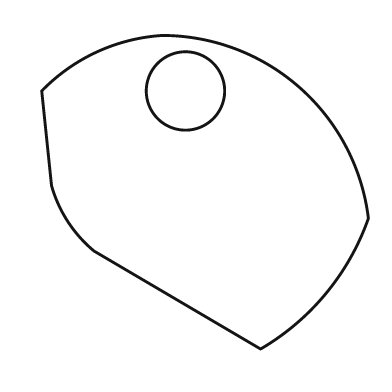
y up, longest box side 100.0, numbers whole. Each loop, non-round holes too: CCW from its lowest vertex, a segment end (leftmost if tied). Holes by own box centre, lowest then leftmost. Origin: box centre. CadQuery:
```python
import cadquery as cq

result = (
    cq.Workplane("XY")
    .moveTo(17.0, -48.0)
    .threePointArc((37.0, -31.0), (50.0, -8.0))
    .threePointArc((29.0, 32.0), (-13.0, 48.0))
    .threePointArc((-33.0, 43.0), (-50.0, 31.0))
    .lineTo(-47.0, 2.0)
    .threePointArc((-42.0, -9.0), (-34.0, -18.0))
    .close()
    .moveTo(-6.0, 31.0)
    .circle(12.0)
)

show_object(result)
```